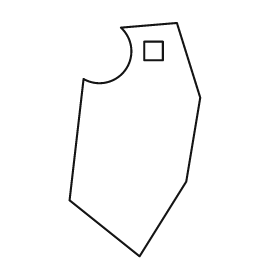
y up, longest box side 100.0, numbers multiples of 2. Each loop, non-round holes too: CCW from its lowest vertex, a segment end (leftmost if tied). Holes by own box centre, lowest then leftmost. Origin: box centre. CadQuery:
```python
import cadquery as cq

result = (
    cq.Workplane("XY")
    .moveTo(2.0, -50.0)
    .lineTo(22.0, -18.0)
    .lineTo(28.0, 18.0)
    .lineTo(18.0, 50.0)
    .lineTo(-6.0, 48.0)
    .threePointArc((-4.0, 30.0), (-22.0, 26.0))
    .lineTo(-28.0, -26.0)
    .close()
    .moveTo(4.0, 34.0)
    .lineTo(12.0, 34.0)
    .lineTo(12.0, 42.0)
    .lineTo(4.0, 42.0)
    .close()
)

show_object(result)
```